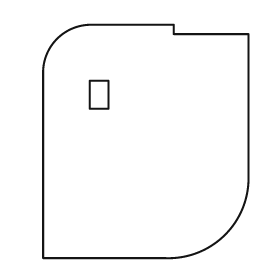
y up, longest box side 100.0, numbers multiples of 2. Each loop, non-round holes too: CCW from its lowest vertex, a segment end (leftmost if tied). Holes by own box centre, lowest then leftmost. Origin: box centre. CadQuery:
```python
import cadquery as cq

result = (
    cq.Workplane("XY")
    .moveTo(-44.0, -50.0)
    .lineTo(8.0, -50.0)
    .threePointArc((34.0, -40.0), (44.0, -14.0))
    .lineTo(44.0, 46.0)
    .lineTo(12.0, 46.0)
    .lineTo(12.0, 50.0)
    .lineTo(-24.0, 50.0)
    .threePointArc((-38.0, 44.0), (-44.0, 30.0))
    .close()
    .moveTo(-24.0, 14.0)
    .lineTo(-16.0, 14.0)
    .lineTo(-16.0, 26.0)
    .lineTo(-24.0, 26.0)
    .close()
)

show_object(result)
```